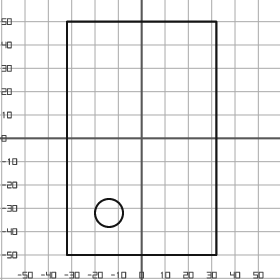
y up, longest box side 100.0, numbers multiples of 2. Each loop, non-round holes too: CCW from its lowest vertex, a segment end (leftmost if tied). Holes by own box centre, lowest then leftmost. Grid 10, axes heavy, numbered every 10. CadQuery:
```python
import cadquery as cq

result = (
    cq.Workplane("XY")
    .moveTo(-32.0, -50.0)
    .lineTo(32.0, -50.0)
    .lineTo(32.0, 50.0)
    .lineTo(-32.0, 50.0)
    .close()
    .moveTo(-14.0, -32.0)
    .circle(6.0)
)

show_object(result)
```